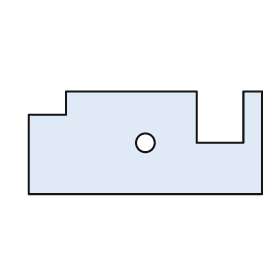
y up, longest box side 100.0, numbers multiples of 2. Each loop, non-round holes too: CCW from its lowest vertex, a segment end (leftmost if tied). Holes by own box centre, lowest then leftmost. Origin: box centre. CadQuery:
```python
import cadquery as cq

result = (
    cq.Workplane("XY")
    .moveTo(-50.0, -22.0)
    .lineTo(50.0, -22.0)
    .lineTo(50.0, 22.0)
    .lineTo(42.0, 22.0)
    .lineTo(42.0, 0.0)
    .lineTo(22.0, 0.0)
    .lineTo(22.0, 22.0)
    .lineTo(-34.0, 22.0)
    .lineTo(-34.0, 12.0)
    .lineTo(-50.0, 12.0)
    .close()
    .moveTo(0.0, 0.0)
    .circle(4.0)
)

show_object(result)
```